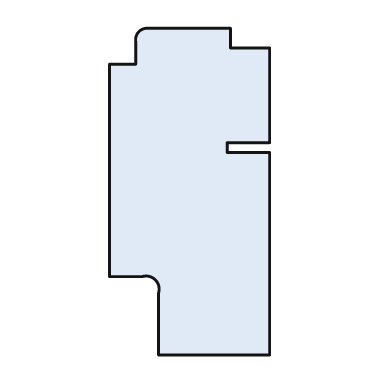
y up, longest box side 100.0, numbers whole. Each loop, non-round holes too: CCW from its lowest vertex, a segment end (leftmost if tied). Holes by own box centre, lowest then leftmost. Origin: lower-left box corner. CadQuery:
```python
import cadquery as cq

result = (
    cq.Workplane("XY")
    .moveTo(15.0, 0.0)
    .lineTo(49.0, 0.0)
    .lineTo(49.0, 62.0)
    .lineTo(36.0, 62.0)
    .lineTo(36.0, 65.0)
    .lineTo(49.0, 65.0)
    .lineTo(49.0, 94.0)
    .lineTo(37.0, 94.0)
    .lineTo(37.0, 100.0)
    .lineTo(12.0, 100.0)
    .threePointArc((9.0, 99.0), (8.0, 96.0))
    .lineTo(8.0, 89.0)
    .lineTo(0.0, 89.0)
    .lineTo(0.0, 24.0)
    .lineTo(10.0, 24.0)
    .threePointArc((14.0, 23.0), (15.0, 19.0))
    .close()
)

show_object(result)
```